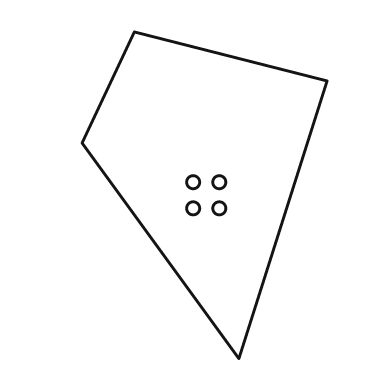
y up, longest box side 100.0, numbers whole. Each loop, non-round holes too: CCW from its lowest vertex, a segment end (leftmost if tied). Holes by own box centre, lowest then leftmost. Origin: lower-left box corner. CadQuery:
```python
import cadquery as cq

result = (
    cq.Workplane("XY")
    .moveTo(48.0, 0.0)
    .lineTo(75.0, 85.0)
    .lineTo(16.0, 100.0)
    .lineTo(0.0, 66.0)
    .close()
    .moveTo(34.0, 46.0)
    .circle(2.0)
    .moveTo(42.0, 46.0)
    .circle(2.0)
    .moveTo(34.0, 54.0)
    .circle(2.0)
    .moveTo(42.0, 54.0)
    .circle(2.0)
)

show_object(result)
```